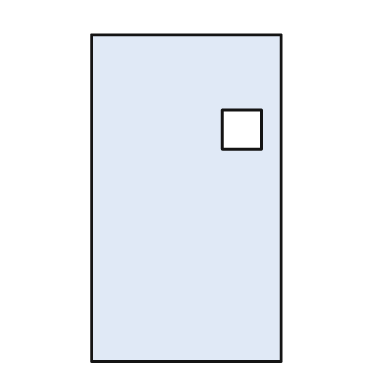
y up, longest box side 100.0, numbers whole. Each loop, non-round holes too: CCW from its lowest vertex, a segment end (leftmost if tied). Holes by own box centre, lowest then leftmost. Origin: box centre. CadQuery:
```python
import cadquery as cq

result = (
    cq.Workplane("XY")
    .moveTo(-29.0, -50.0)
    .lineTo(29.0, -50.0)
    .lineTo(29.0, 50.0)
    .lineTo(-29.0, 50.0)
    .close()
    .moveTo(11.0, 15.0)
    .lineTo(23.0, 15.0)
    .lineTo(23.0, 27.0)
    .lineTo(11.0, 27.0)
    .close()
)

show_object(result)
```